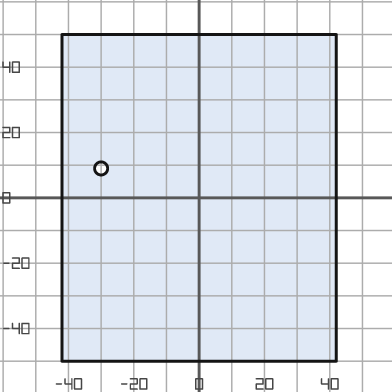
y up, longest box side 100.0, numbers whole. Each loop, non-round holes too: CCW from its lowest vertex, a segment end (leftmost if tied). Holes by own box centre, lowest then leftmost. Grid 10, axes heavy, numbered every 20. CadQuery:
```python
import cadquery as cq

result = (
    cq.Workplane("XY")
    .moveTo(-42.0, -50.0)
    .lineTo(42.0, -50.0)
    .lineTo(42.0, 50.0)
    .lineTo(-42.0, 50.0)
    .close()
    .moveTo(-30.0, 9.0)
    .circle(2.0)
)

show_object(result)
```